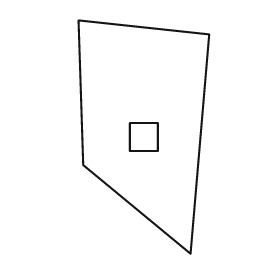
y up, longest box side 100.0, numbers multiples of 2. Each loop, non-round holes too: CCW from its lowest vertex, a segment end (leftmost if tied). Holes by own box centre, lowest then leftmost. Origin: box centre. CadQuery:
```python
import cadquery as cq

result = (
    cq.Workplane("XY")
    .moveTo(20.0, -50.0)
    .lineTo(28.0, 44.0)
    .lineTo(-28.0, 50.0)
    .lineTo(-26.0, -12.0)
    .close()
    .moveTo(-6.0, -6.0)
    .lineTo(6.0, -6.0)
    .lineTo(6.0, 6.0)
    .lineTo(-6.0, 6.0)
    .close()
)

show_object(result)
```